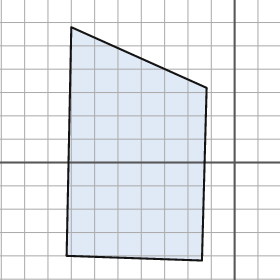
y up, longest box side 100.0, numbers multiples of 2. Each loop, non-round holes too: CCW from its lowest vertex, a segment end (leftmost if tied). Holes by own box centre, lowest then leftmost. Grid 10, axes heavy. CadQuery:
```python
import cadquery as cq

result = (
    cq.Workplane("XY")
    .moveTo(-14.0, -42.0)
    .lineTo(-12.0, 32.0)
    .lineTo(-70.0, 58.0)
    .lineTo(-72.0, -40.0)
    .close()
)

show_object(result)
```